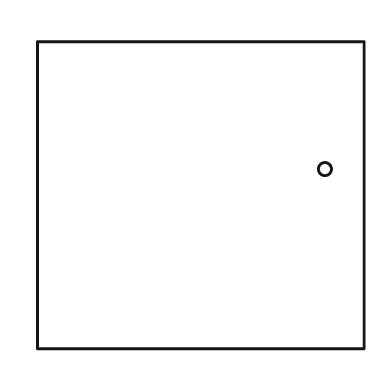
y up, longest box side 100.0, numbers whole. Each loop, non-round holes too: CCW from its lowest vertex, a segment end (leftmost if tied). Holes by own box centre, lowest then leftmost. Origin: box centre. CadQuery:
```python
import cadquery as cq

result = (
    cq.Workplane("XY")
    .moveTo(-50.0, -47.0)
    .lineTo(50.0, -47.0)
    .lineTo(50.0, 47.0)
    .lineTo(-50.0, 47.0)
    .close()
    .moveTo(38.0, 8.0)
    .circle(2.0)
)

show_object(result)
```